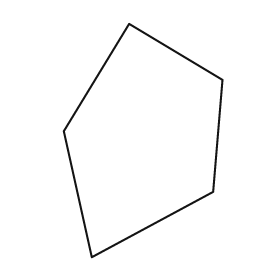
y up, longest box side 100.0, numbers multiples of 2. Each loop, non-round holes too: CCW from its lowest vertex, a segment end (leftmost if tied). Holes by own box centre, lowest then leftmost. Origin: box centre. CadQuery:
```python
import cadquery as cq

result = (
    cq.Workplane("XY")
    .moveTo(-22.0, -50.0)
    .lineTo(30.0, -22.0)
    .lineTo(34.0, 26.0)
    .lineTo(-6.0, 50.0)
    .lineTo(-34.0, 4.0)
    .close()
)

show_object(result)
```